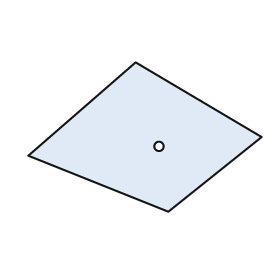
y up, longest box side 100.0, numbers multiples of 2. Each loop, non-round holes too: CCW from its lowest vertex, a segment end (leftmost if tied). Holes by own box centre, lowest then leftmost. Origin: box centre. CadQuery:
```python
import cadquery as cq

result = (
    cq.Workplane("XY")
    .moveTo(10.0, -32.0)
    .lineTo(50.0, 0.0)
    .lineTo(-4.0, 32.0)
    .lineTo(-50.0, -8.0)
    .close()
    .moveTo(6.0, -4.0)
    .circle(2.0)
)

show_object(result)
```